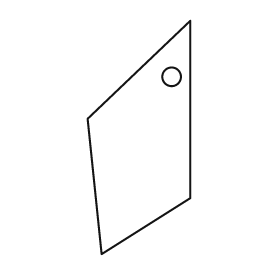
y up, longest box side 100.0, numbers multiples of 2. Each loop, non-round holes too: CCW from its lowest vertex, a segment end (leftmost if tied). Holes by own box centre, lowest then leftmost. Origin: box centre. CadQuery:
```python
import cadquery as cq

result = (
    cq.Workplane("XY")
    .moveTo(-16.0, -50.0)
    .lineTo(22.0, -26.0)
    .lineTo(22.0, 50.0)
    .lineTo(-22.0, 8.0)
    .close()
    .moveTo(14.0, 26.0)
    .circle(4.0)
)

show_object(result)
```